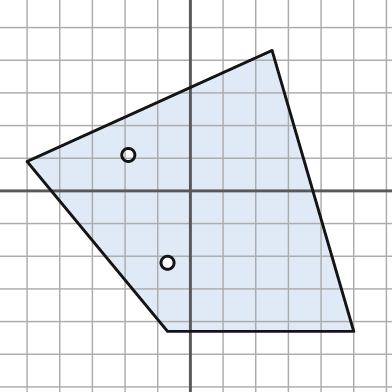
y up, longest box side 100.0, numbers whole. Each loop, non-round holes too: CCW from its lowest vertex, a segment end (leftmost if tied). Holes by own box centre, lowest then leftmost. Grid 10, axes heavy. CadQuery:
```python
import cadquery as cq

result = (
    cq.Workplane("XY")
    .moveTo(-7.0, -43.0)
    .lineTo(50.0, -43.0)
    .lineTo(25.0, 43.0)
    .lineTo(-50.0, 9.0)
    .close()
    .moveTo(-7.0, -22.0)
    .circle(2.0)
    .moveTo(-19.0, 11.0)
    .circle(2.0)
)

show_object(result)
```